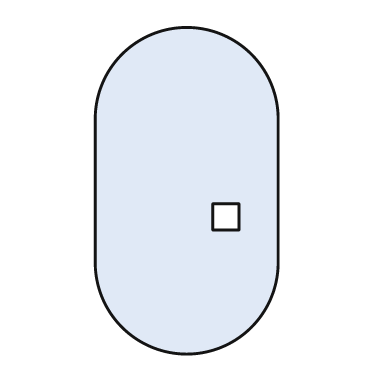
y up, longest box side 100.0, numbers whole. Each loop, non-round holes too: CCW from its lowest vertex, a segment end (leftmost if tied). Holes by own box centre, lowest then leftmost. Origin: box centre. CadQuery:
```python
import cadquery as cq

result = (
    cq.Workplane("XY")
    .moveTo(-28.0, -22.0)
    .threePointArc((0.0, -50.0), (28.0, -22.0))
    .lineTo(28.0, 22.0)
    .threePointArc((0.0, 50.0), (-28.0, 22.0))
    .close()
    .moveTo(8.0, -12.0)
    .lineTo(16.0, -12.0)
    .lineTo(16.0, -4.0)
    .lineTo(8.0, -4.0)
    .close()
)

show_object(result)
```